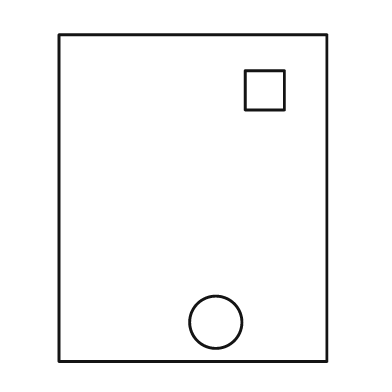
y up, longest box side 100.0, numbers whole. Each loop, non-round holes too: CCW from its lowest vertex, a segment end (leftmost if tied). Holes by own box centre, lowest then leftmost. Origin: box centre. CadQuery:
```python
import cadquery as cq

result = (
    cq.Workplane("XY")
    .moveTo(-41.0, -50.0)
    .lineTo(41.0, -50.0)
    .lineTo(41.0, 50.0)
    .lineTo(-41.0, 50.0)
    .close()
    .moveTo(7.0, -38.0)
    .circle(8.0)
    .moveTo(16.0, 27.0)
    .lineTo(28.0, 27.0)
    .lineTo(28.0, 39.0)
    .lineTo(16.0, 39.0)
    .close()
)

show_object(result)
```